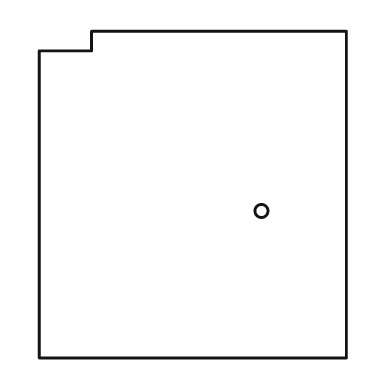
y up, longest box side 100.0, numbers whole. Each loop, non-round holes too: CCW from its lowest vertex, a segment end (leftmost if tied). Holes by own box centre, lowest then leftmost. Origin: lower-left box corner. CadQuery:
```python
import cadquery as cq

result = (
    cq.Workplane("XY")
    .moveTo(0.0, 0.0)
    .lineTo(94.0, 0.0)
    .lineTo(94.0, 100.0)
    .lineTo(16.0, 100.0)
    .lineTo(16.0, 94.0)
    .lineTo(0.0, 94.0)
    .close()
    .moveTo(68.0, 45.0)
    .circle(2.0)
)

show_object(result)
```